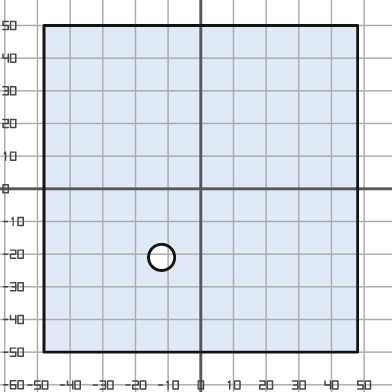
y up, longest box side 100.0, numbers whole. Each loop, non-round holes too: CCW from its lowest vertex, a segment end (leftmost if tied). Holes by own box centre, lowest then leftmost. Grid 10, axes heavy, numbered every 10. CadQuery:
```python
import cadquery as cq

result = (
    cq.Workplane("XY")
    .moveTo(-48.0, -50.0)
    .lineTo(48.0, -50.0)
    .lineTo(48.0, 50.0)
    .lineTo(-48.0, 50.0)
    .close()
    .moveTo(-12.0, -21.0)
    .circle(4.0)
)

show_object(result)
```